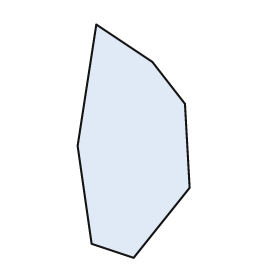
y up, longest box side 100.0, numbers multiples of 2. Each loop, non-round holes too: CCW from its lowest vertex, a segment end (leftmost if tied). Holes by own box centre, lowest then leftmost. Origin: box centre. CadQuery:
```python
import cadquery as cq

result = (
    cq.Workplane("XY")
    .moveTo(0.0, -50.0)
    .lineTo(24.0, -20.0)
    .lineTo(22.0, 16.0)
    .lineTo(8.0, 34.0)
    .lineTo(-16.0, 50.0)
    .lineTo(-24.0, -2.0)
    .lineTo(-18.0, -44.0)
    .close()
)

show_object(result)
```